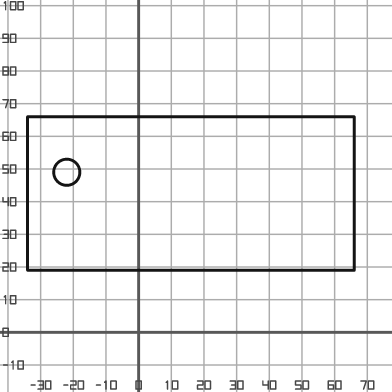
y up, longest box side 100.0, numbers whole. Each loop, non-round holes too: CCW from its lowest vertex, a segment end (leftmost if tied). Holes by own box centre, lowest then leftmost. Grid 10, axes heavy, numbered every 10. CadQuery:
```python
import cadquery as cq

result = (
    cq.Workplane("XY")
    .moveTo(-34.0, 19.0)
    .lineTo(66.0, 19.0)
    .lineTo(66.0, 66.0)
    .lineTo(-34.0, 66.0)
    .close()
    .moveTo(-22.0, 49.0)
    .circle(4.0)
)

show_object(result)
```